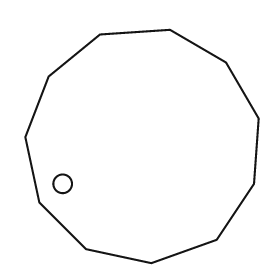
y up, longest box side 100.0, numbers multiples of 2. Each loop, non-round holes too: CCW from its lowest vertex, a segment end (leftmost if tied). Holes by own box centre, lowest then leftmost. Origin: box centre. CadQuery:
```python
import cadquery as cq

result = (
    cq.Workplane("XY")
    .moveTo(4.0, -50.0)
    .lineTo(32.0, -40.0)
    .lineTo(48.0, -16.0)
    .lineTo(50.0, 12.0)
    .lineTo(36.0, 36.0)
    .lineTo(12.0, 50.0)
    .lineTo(-18.0, 48.0)
    .lineTo(-40.0, 30.0)
    .lineTo(-50.0, 4.0)
    .lineTo(-44.0, -24.0)
    .lineTo(-24.0, -44.0)
    .close()
    .moveTo(-34.0, -16.0)
    .circle(4.0)
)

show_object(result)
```